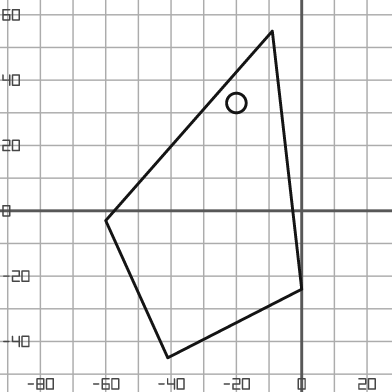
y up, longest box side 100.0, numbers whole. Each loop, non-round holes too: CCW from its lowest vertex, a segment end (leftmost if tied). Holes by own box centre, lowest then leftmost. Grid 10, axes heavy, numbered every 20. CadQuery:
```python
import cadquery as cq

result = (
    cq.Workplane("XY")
    .moveTo(-41.0, -45.0)
    .lineTo(0.0, -24.0)
    .lineTo(-9.0, 55.0)
    .lineTo(-60.0, -3.0)
    .close()
    .moveTo(-20.0, 33.0)
    .circle(3.0)
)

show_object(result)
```